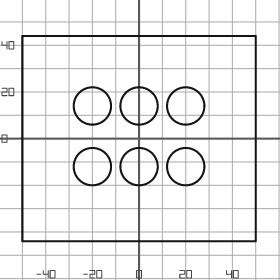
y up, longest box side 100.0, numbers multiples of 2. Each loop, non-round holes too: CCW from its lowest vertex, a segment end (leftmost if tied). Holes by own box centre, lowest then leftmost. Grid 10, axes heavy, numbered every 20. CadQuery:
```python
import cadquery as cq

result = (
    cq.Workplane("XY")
    .moveTo(-50.0, -44.0)
    .lineTo(50.0, -44.0)
    .lineTo(50.0, 44.0)
    .lineTo(-50.0, 44.0)
    .close()
    .moveTo(-20.0, -12.0)
    .circle(8.0)
    .moveTo(0.0, -12.0)
    .circle(8.0)
    .moveTo(20.0, -12.0)
    .circle(8.0)
    .moveTo(-20.0, 14.0)
    .circle(8.0)
    .moveTo(0.0, 14.0)
    .circle(8.0)
    .moveTo(20.0, 14.0)
    .circle(8.0)
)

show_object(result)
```